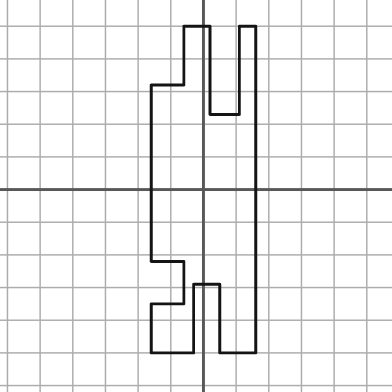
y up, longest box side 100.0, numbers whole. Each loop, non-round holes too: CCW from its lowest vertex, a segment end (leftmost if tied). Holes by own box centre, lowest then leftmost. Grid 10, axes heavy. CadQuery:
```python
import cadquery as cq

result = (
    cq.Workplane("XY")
    .moveTo(-16.0, -50.0)
    .lineTo(-3.0, -50.0)
    .lineTo(-3.0, -29.0)
    .lineTo(5.0, -29.0)
    .lineTo(5.0, -50.0)
    .lineTo(16.0, -50.0)
    .lineTo(16.0, 50.0)
    .lineTo(11.0, 50.0)
    .lineTo(11.0, 23.0)
    .lineTo(2.0, 23.0)
    .lineTo(2.0, 50.0)
    .lineTo(-6.0, 50.0)
    .lineTo(-6.0, 32.0)
    .lineTo(-16.0, 32.0)
    .lineTo(-16.0, -22.0)
    .lineTo(-6.0, -22.0)
    .lineTo(-6.0, -35.0)
    .lineTo(-16.0, -35.0)
    .close()
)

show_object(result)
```